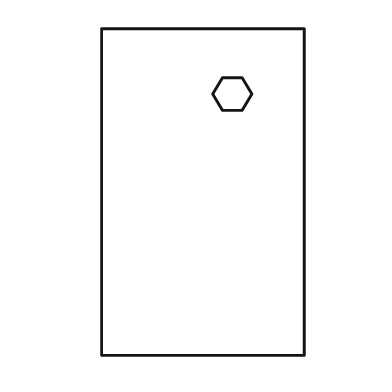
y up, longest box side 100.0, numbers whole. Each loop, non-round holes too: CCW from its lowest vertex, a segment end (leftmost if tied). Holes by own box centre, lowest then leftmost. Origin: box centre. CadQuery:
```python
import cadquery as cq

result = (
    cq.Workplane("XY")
    .moveTo(-31.0, -50.0)
    .lineTo(31.0, -50.0)
    .lineTo(31.0, 50.0)
    .lineTo(-31.0, 50.0)
    .close()
    .moveTo(6.0, 25.0)
    .lineTo(12.0, 25.0)
    .lineTo(15.0, 30.0)
    .lineTo(12.0, 35.0)
    .lineTo(6.0, 35.0)
    .lineTo(3.0, 30.0)
    .close()
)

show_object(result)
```